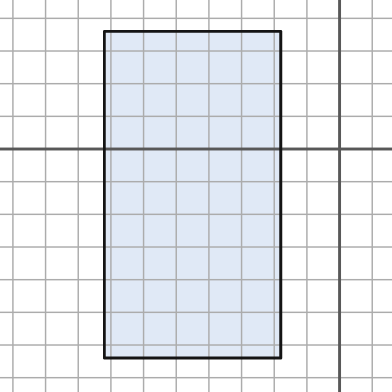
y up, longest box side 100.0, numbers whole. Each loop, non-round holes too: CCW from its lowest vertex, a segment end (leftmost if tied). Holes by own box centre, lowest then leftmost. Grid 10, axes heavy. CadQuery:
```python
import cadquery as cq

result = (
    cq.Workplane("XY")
    .moveTo(-72.0, -64.0)
    .lineTo(-18.0, -64.0)
    .lineTo(-18.0, 36.0)
    .lineTo(-72.0, 36.0)
    .close()
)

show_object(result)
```